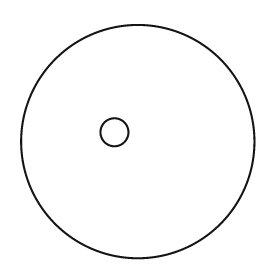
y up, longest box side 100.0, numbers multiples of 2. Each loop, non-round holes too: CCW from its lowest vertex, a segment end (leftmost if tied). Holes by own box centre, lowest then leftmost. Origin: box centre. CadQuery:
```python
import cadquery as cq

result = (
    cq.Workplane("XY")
    .moveTo(0.0, 0.0)
    .circle(50.0)
    .moveTo(-10.0, 4.0)
    .circle(6.0)
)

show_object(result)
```